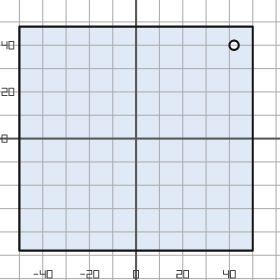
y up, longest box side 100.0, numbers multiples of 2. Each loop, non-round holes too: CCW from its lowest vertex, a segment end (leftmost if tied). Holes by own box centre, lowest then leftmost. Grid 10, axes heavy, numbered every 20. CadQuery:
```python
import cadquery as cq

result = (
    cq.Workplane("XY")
    .moveTo(-50.0, -48.0)
    .lineTo(50.0, -48.0)
    .lineTo(50.0, 48.0)
    .lineTo(-50.0, 48.0)
    .close()
    .moveTo(42.0, 40.0)
    .circle(2.0)
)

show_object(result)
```